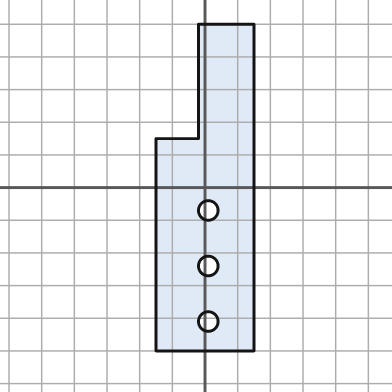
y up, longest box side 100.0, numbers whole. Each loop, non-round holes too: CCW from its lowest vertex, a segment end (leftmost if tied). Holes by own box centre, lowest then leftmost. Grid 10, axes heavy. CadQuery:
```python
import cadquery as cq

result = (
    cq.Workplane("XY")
    .moveTo(-15.0, -50.0)
    .lineTo(15.0, -50.0)
    .lineTo(15.0, 50.0)
    .lineTo(-2.0, 50.0)
    .lineTo(-2.0, 15.0)
    .lineTo(-15.0, 15.0)
    .close()
    .moveTo(1.0, -41.0)
    .circle(3.0)
    .moveTo(1.0, -24.0)
    .circle(3.0)
    .moveTo(1.0, -7.0)
    .circle(3.0)
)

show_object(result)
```